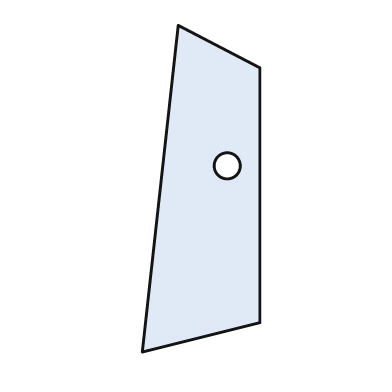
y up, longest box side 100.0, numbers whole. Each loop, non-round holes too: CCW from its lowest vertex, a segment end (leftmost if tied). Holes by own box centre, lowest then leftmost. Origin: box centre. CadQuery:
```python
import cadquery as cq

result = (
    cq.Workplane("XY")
    .moveTo(-18.0, -50.0)
    .lineTo(18.0, -41.0)
    .lineTo(18.0, 37.0)
    .lineTo(-7.0, 50.0)
    .close()
    .moveTo(8.0, 7.0)
    .circle(4.0)
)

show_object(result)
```